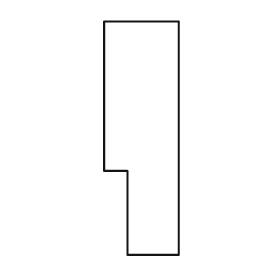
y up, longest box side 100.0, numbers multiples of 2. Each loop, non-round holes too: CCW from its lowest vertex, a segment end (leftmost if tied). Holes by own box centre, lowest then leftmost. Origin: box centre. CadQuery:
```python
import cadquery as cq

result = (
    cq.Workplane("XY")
    .moveTo(-6.0, -50.0)
    .lineTo(16.0, -50.0)
    .lineTo(16.0, 50.0)
    .lineTo(-16.0, 50.0)
    .lineTo(-16.0, -14.0)
    .lineTo(-6.0, -14.0)
    .close()
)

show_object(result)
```